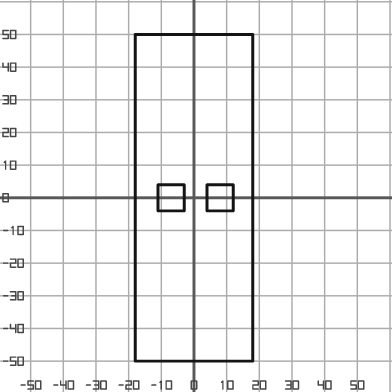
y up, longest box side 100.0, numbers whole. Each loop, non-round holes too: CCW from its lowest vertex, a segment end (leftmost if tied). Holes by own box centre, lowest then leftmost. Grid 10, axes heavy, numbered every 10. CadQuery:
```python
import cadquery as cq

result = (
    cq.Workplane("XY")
    .moveTo(-18.0, -50.0)
    .lineTo(18.0, -50.0)
    .lineTo(18.0, 50.0)
    .lineTo(-18.0, 50.0)
    .close()
    .moveTo(-11.0, -4.0)
    .lineTo(-3.0, -4.0)
    .lineTo(-3.0, 4.0)
    .lineTo(-11.0, 4.0)
    .close()
    .moveTo(4.0, -4.0)
    .lineTo(12.0, -4.0)
    .lineTo(12.0, 4.0)
    .lineTo(4.0, 4.0)
    .close()
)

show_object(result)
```